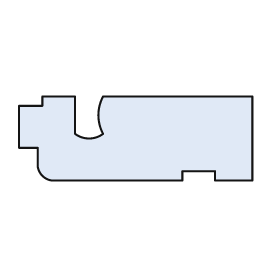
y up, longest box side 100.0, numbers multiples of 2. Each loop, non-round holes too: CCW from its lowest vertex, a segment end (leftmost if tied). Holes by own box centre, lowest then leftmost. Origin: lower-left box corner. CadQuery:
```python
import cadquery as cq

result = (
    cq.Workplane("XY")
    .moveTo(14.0, 0.0)
    .lineTo(70.0, 0.0)
    .lineTo(70.0, 4.0)
    .lineTo(84.0, 4.0)
    .lineTo(84.0, 0.0)
    .lineTo(100.0, 0.0)
    .lineTo(100.0, 36.0)
    .lineTo(36.0, 36.0)
    .threePointArc((34.0, 28.0), (36.0, 20.0))
    .threePointArc((30.0, 18.0), (24.0, 20.0))
    .lineTo(24.0, 36.0)
    .lineTo(10.0, 36.0)
    .lineTo(10.0, 32.0)
    .lineTo(0.0, 32.0)
    .lineTo(0.0, 14.0)
    .lineTo(8.0, 14.0)
    .lineTo(8.0, 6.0)
    .threePointArc((10.0, 2.0), (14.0, 0.0))
    .close()
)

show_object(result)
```